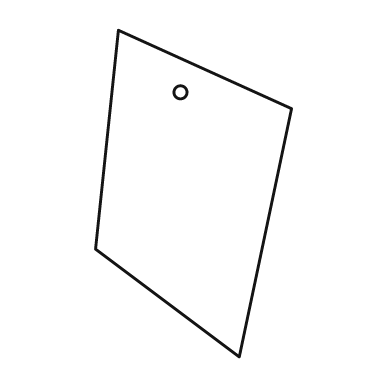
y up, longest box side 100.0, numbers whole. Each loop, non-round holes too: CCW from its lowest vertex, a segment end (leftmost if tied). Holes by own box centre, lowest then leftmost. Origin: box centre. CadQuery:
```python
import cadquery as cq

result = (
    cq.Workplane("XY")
    .moveTo(14.0, -50.0)
    .lineTo(30.0, 26.0)
    .lineTo(-23.0, 50.0)
    .lineTo(-30.0, -17.0)
    .close()
    .moveTo(-4.0, 31.0)
    .circle(2.0)
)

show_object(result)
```